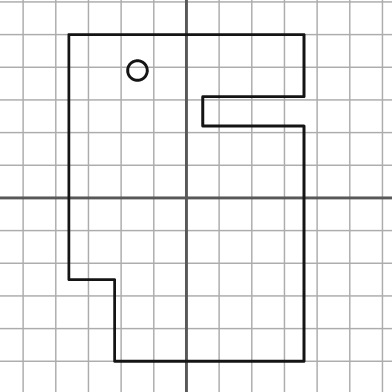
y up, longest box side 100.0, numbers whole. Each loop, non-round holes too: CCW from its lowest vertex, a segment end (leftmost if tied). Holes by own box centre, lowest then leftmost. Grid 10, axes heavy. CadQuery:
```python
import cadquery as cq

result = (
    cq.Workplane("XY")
    .moveTo(-22.0, -50.0)
    .lineTo(36.0, -50.0)
    .lineTo(36.0, 22.0)
    .lineTo(5.0, 22.0)
    .lineTo(5.0, 31.0)
    .lineTo(36.0, 31.0)
    .lineTo(36.0, 50.0)
    .lineTo(-36.0, 50.0)
    .lineTo(-36.0, -25.0)
    .lineTo(-22.0, -25.0)
    .close()
    .moveTo(-15.0, 39.0)
    .circle(3.0)
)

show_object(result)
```